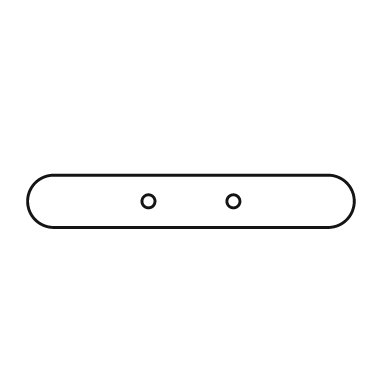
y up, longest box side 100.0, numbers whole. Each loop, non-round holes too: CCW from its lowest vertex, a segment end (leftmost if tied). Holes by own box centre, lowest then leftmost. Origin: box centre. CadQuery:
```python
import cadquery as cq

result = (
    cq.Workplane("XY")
    .moveTo(-42.0, -8.0)
    .lineTo(42.0, -8.0)
    .threePointArc((50.0, 0.0), (42.0, 8.0))
    .lineTo(-42.0, 8.0)
    .threePointArc((-50.0, 0.0), (-42.0, -8.0))
    .close()
    .moveTo(-13.0, 0.0)
    .circle(2.0)
    .moveTo(13.0, 0.0)
    .circle(2.0)
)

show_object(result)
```